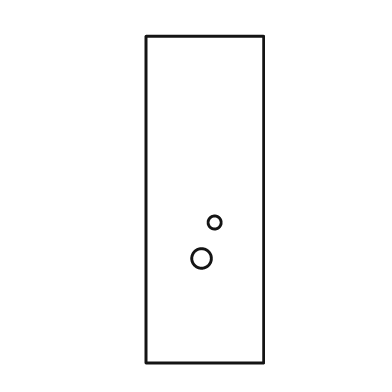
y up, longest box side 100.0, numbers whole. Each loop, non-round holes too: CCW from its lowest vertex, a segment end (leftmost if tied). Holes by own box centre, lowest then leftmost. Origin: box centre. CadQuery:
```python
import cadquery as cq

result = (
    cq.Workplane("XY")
    .moveTo(-18.0, -50.0)
    .lineTo(18.0, -50.0)
    .lineTo(18.0, 50.0)
    .lineTo(-18.0, 50.0)
    .close()
    .moveTo(-1.0, -18.0)
    .circle(3.0)
    .moveTo(3.0, -7.0)
    .circle(2.0)
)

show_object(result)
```